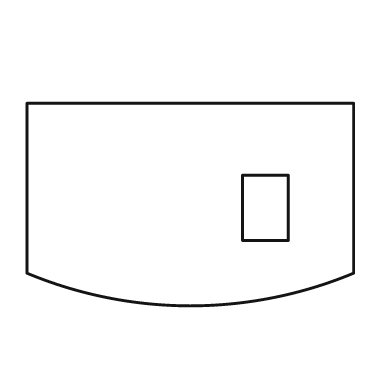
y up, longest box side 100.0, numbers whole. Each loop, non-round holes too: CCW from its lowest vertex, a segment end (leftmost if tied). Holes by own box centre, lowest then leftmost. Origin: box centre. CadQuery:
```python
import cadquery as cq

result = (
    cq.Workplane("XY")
    .moveTo(-50.0, -21.0)
    .threePointArc((0.0, -31.0), (50.0, -21.0))
    .lineTo(50.0, 31.0)
    .lineTo(-50.0, 31.0)
    .close()
    .moveTo(16.0, -11.0)
    .lineTo(30.0, -11.0)
    .lineTo(30.0, 9.0)
    .lineTo(16.0, 9.0)
    .close()
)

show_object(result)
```